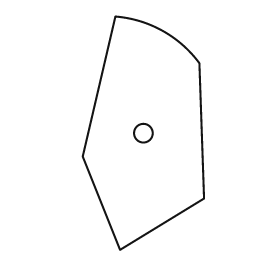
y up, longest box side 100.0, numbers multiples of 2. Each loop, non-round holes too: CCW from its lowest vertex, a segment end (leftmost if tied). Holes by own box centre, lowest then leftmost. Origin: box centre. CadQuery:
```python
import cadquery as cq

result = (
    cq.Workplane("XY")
    .moveTo(-10.0, -50.0)
    .lineTo(26.0, -28.0)
    .lineTo(24.0, 30.0)
    .threePointArc((8.0, 44.0), (-12.0, 50.0))
    .lineTo(-26.0, -10.0)
    .close()
    .moveTo(0.0, 0.0)
    .circle(4.0)
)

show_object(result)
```